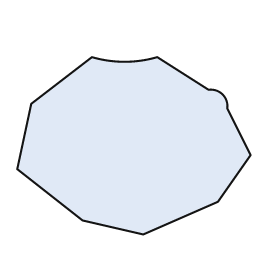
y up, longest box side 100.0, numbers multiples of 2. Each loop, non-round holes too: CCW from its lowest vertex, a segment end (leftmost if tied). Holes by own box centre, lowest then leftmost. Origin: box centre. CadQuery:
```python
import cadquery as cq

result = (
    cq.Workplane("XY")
    .moveTo(4.0, -38.0)
    .lineTo(36.0, -24.0)
    .lineTo(50.0, -4.0)
    .lineTo(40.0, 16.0)
    .threePointArc((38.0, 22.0), (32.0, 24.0))
    .lineTo(10.0, 38.0)
    .threePointArc((-4.0, 36.0), (-18.0, 38.0))
    .lineTo(-44.0, 18.0)
    .lineTo(-50.0, -10.0)
    .lineTo(-22.0, -32.0)
    .close()
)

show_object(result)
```